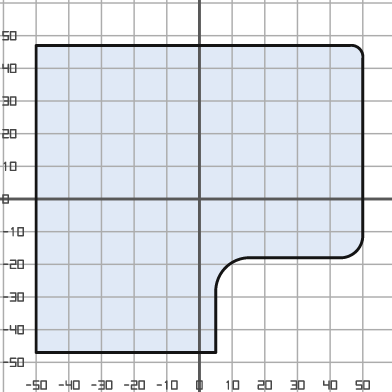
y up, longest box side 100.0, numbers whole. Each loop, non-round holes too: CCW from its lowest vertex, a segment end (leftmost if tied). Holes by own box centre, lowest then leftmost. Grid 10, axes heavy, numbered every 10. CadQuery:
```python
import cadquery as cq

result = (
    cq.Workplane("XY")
    .moveTo(-50.0, -47.0)
    .lineTo(5.0, -47.0)
    .lineTo(5.0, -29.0)
    .threePointArc((8.0, -21.0), (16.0, -18.0))
    .lineTo(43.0, -18.0)
    .threePointArc((48.0, -16.0), (50.0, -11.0))
    .lineTo(50.0, 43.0)
    .threePointArc((49.0, 46.0), (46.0, 47.0))
    .lineTo(-50.0, 47.0)
    .close()
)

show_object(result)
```